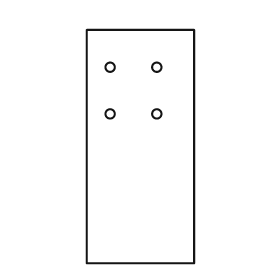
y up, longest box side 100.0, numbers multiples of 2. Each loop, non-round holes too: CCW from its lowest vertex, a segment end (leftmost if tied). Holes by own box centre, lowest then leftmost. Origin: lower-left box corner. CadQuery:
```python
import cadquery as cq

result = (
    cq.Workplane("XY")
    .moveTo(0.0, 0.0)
    .lineTo(46.0, 0.0)
    .lineTo(46.0, 100.0)
    .lineTo(0.0, 100.0)
    .close()
    .moveTo(10.0, 64.0)
    .circle(2.0)
    .moveTo(30.0, 64.0)
    .circle(2.0)
    .moveTo(10.0, 84.0)
    .circle(2.0)
    .moveTo(30.0, 84.0)
    .circle(2.0)
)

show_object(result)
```